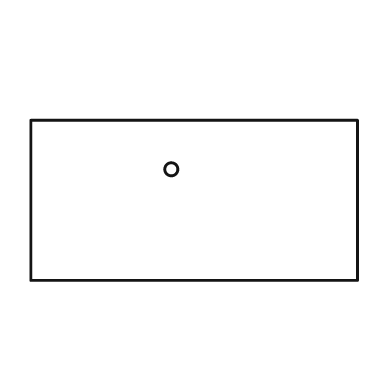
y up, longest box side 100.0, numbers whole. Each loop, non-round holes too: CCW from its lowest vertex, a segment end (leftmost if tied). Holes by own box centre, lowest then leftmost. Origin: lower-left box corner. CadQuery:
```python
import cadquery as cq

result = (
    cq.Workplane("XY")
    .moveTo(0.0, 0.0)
    .lineTo(100.0, 0.0)
    .lineTo(100.0, 49.0)
    .lineTo(0.0, 49.0)
    .close()
    .moveTo(43.0, 34.0)
    .circle(2.0)
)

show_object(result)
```